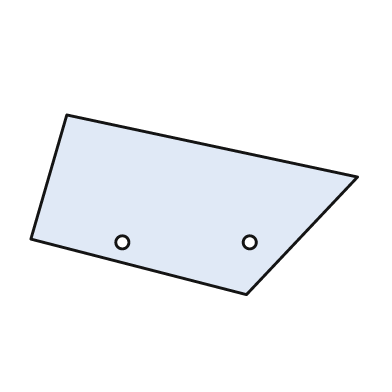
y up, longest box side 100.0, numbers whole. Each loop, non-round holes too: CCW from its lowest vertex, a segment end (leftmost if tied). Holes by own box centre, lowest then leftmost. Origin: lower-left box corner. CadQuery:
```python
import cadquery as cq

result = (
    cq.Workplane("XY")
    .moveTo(66.0, 0.0)
    .lineTo(100.0, 36.0)
    .lineTo(11.0, 55.0)
    .lineTo(0.0, 17.0)
    .close()
    .moveTo(28.0, 16.0)
    .circle(2.0)
    .moveTo(67.0, 16.0)
    .circle(2.0)
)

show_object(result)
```